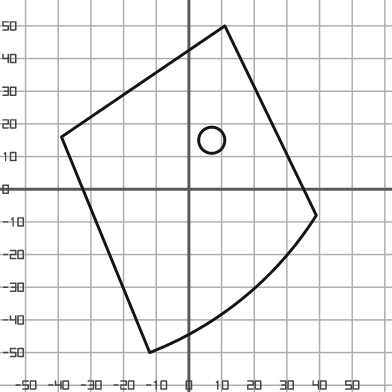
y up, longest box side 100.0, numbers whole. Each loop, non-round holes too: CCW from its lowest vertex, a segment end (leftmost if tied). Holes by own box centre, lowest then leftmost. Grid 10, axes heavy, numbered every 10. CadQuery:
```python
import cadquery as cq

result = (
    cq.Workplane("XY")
    .moveTo(-12.0, -50.0)
    .threePointArc((17.0, -33.0), (39.0, -8.0))
    .lineTo(11.0, 50.0)
    .lineTo(-39.0, 16.0)
    .close()
    .moveTo(7.0, 15.0)
    .circle(4.0)
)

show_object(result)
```